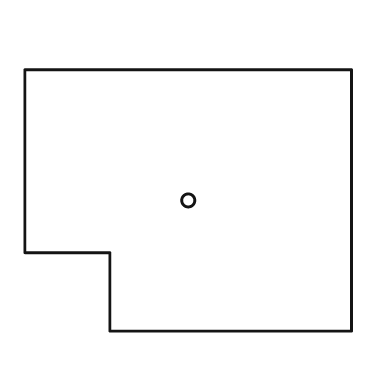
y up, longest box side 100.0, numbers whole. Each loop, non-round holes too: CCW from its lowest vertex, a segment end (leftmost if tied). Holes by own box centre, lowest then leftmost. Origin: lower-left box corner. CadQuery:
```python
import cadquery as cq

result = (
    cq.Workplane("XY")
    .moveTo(26.0, 0.0)
    .lineTo(100.0, 0.0)
    .lineTo(100.0, 80.0)
    .lineTo(0.0, 80.0)
    .lineTo(0.0, 24.0)
    .lineTo(26.0, 24.0)
    .close()
    .moveTo(50.0, 40.0)
    .circle(2.0)
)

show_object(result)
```